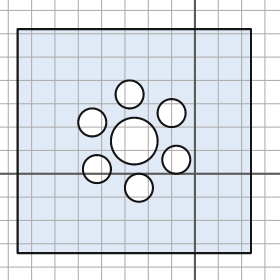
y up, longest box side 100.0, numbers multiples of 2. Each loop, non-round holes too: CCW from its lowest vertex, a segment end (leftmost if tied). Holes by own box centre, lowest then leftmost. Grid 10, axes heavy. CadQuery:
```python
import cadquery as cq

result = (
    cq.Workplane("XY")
    .moveTo(-76.0, -34.0)
    .lineTo(24.0, -34.0)
    .lineTo(24.0, 62.0)
    .lineTo(-76.0, 62.0)
    .close()
    .moveTo(-24.0, -6.0)
    .circle(6.0)
    .moveTo(-42.0, 2.0)
    .circle(6.0)
    .moveTo(-8.0, 6.0)
    .circle(6.0)
    .moveTo(-26.0, 14.0)
    .circle(10.0)
    .moveTo(-44.0, 22.0)
    .circle(6.0)
    .moveTo(-10.0, 26.0)
    .circle(6.0)
    .moveTo(-28.0, 34.0)
    .circle(6.0)
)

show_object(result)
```